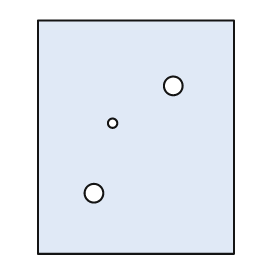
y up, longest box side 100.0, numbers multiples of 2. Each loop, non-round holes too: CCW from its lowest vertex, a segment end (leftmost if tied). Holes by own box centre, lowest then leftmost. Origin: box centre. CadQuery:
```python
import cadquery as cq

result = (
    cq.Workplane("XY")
    .moveTo(-42.0, -50.0)
    .lineTo(42.0, -50.0)
    .lineTo(42.0, 50.0)
    .lineTo(-42.0, 50.0)
    .close()
    .moveTo(-18.0, -24.0)
    .circle(4.0)
    .moveTo(-10.0, 6.0)
    .circle(2.0)
    .moveTo(16.0, 22.0)
    .circle(4.0)
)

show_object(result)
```